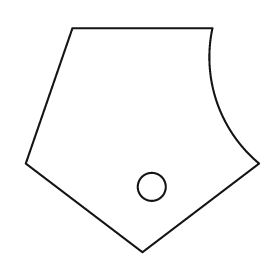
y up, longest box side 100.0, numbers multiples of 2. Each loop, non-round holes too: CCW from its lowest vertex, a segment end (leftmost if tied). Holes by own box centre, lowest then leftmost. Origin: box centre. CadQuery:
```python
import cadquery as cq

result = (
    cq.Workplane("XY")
    .moveTo(0.0, -48.0)
    .lineTo(50.0, -10.0)
    .threePointArc((32.0, 16.0), (30.0, 48.0))
    .lineTo(-30.0, 48.0)
    .lineTo(-50.0, -10.0)
    .close()
    .moveTo(4.0, -20.0)
    .circle(6.0)
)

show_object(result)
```